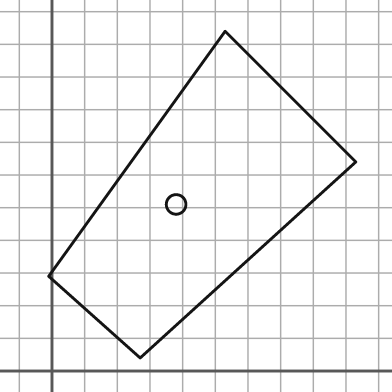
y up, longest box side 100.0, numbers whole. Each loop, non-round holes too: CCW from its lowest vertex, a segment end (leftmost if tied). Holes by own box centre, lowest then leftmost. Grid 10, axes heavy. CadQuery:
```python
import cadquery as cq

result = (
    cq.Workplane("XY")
    .moveTo(27.0, 4.0)
    .lineTo(93.0, 64.0)
    .lineTo(53.0, 104.0)
    .lineTo(-1.0, 29.0)
    .close()
    .moveTo(38.0, 51.0)
    .circle(3.0)
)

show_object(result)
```